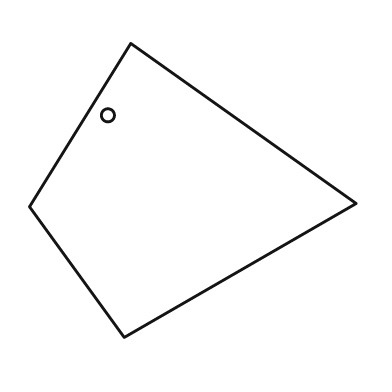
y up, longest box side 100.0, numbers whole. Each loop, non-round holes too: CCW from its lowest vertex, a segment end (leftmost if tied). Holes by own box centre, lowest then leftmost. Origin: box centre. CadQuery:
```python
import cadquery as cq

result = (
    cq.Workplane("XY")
    .moveTo(-21.0, -45.0)
    .lineTo(50.0, -4.0)
    .lineTo(-19.0, 45.0)
    .lineTo(-50.0, -5.0)
    .close()
    .moveTo(-26.0, 23.0)
    .circle(2.0)
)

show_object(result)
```